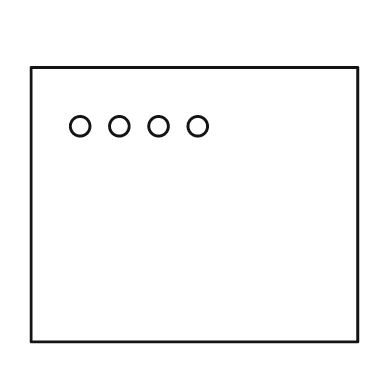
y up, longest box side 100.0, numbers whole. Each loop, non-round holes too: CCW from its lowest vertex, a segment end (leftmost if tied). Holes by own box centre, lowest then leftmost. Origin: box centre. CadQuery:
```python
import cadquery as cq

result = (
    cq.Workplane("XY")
    .moveTo(-50.0, -42.0)
    .lineTo(50.0, -42.0)
    .lineTo(50.0, 42.0)
    .lineTo(-50.0, 42.0)
    .close()
    .moveTo(-35.0, 24.0)
    .circle(3.0)
    .moveTo(-23.0, 24.0)
    .circle(3.0)
    .moveTo(-11.0, 24.0)
    .circle(3.0)
    .moveTo(1.0, 24.0)
    .circle(3.0)
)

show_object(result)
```